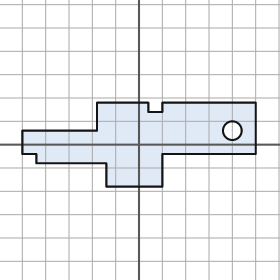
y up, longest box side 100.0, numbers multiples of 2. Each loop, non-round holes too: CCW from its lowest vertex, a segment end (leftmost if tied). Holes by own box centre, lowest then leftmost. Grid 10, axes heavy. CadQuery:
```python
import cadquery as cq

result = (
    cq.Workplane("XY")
    .moveTo(-14.0, -18.0)
    .lineTo(10.0, -18.0)
    .lineTo(10.0, -4.0)
    .lineTo(50.0, -4.0)
    .lineTo(50.0, 18.0)
    .lineTo(10.0, 18.0)
    .lineTo(10.0, 14.0)
    .lineTo(4.0, 14.0)
    .lineTo(4.0, 18.0)
    .lineTo(-18.0, 18.0)
    .lineTo(-18.0, 6.0)
    .lineTo(-50.0, 6.0)
    .lineTo(-50.0, -4.0)
    .lineTo(-44.0, -4.0)
    .lineTo(-44.0, -8.0)
    .lineTo(-14.0, -8.0)
    .close()
    .moveTo(40.0, 6.0)
    .circle(4.0)
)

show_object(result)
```